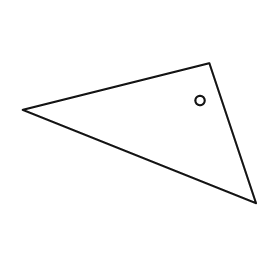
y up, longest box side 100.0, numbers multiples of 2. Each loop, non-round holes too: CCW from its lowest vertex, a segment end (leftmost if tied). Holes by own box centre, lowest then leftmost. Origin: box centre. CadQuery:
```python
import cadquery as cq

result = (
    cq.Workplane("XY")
    .moveTo(50.0, -30.0)
    .lineTo(30.0, 30.0)
    .lineTo(-50.0, 10.0)
    .close()
    .moveTo(26.0, 14.0)
    .circle(2.0)
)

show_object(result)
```